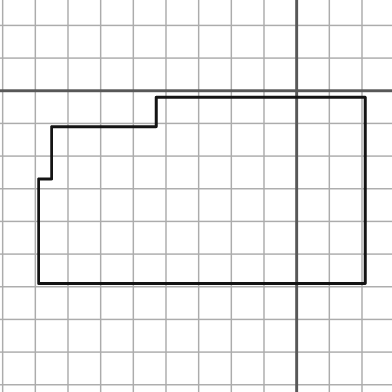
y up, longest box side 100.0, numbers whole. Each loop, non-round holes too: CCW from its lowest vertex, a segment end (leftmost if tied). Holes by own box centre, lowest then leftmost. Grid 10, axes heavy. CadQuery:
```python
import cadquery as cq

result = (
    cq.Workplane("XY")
    .moveTo(-79.0, -59.0)
    .lineTo(21.0, -59.0)
    .lineTo(21.0, -2.0)
    .lineTo(-43.0, -2.0)
    .lineTo(-43.0, -11.0)
    .lineTo(-75.0, -11.0)
    .lineTo(-75.0, -27.0)
    .lineTo(-79.0, -27.0)
    .close()
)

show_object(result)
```